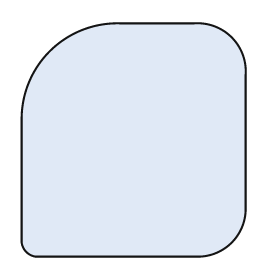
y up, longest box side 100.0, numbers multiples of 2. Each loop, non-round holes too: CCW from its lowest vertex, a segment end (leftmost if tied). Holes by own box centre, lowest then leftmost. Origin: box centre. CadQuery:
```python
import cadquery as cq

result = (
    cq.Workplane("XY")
    .moveTo(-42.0, -50.0)
    .lineTo(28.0, -50.0)
    .threePointArc((42.0, -44.0), (48.0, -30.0))
    .lineTo(48.0, 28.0)
    .threePointArc((42.0, 44.0), (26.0, 50.0))
    .lineTo(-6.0, 50.0)
    .threePointArc((-36.0, 38.0), (-48.0, 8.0))
    .lineTo(-48.0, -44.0)
    .threePointArc((-46.0, -48.0), (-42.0, -50.0))
    .close()
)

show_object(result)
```